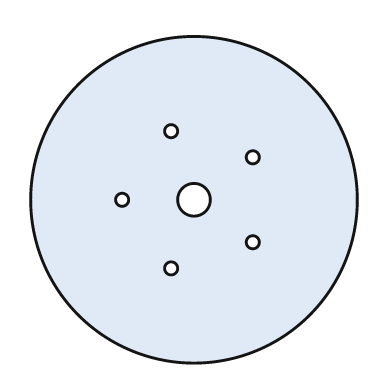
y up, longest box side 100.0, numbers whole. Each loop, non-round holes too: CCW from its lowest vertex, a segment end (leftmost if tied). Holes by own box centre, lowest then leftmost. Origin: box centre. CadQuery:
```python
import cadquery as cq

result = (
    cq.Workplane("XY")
    .moveTo(0.0, 0.0)
    .circle(50.0)
    .moveTo(-7.0, -21.0)
    .circle(2.0)
    .moveTo(18.0, -13.0)
    .circle(2.0)
    .moveTo(-22.0, 0.0)
    .circle(2.0)
    .moveTo(0.0, 0.0)
    .circle(5.0)
    .moveTo(18.0, 13.0)
    .circle(2.0)
    .moveTo(-7.0, 21.0)
    .circle(2.0)
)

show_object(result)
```